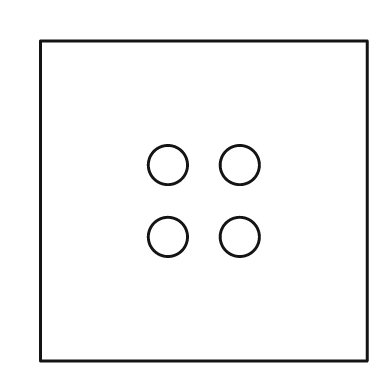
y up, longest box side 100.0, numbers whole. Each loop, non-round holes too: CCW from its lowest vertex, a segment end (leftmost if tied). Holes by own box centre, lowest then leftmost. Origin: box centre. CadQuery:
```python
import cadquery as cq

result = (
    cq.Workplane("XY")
    .moveTo(-50.0, -49.0)
    .lineTo(50.0, -49.0)
    .lineTo(50.0, 49.0)
    .lineTo(-50.0, 49.0)
    .close()
    .moveTo(-11.0, -11.0)
    .circle(6.0)
    .moveTo(11.0, -11.0)
    .circle(6.0)
    .moveTo(-11.0, 11.0)
    .circle(6.0)
    .moveTo(11.0, 11.0)
    .circle(6.0)
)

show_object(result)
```